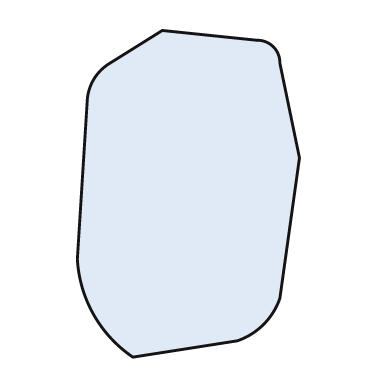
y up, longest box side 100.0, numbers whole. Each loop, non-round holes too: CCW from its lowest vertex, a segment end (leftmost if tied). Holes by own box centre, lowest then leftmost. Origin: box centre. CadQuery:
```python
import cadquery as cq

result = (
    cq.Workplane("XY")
    .moveTo(-17.0, -50.0)
    .lineTo(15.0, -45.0)
    .threePointArc((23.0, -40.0), (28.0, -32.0))
    .lineTo(34.0, 11.0)
    .lineTo(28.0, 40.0)
    .threePointArc((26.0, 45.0), (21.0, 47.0))
    .lineTo(-8.0, 50.0)
    .lineTo(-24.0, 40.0)
    .threePointArc((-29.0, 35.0), (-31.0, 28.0))
    .lineTo(-34.0, -20.0)
    .threePointArc((-29.0, -37.0), (-17.0, -50.0))
    .close()
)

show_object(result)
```